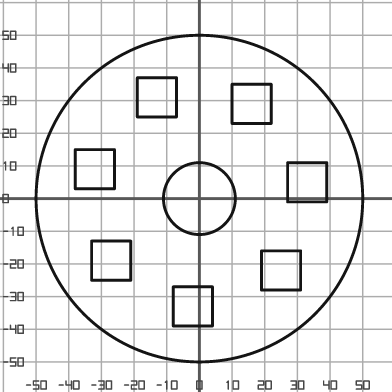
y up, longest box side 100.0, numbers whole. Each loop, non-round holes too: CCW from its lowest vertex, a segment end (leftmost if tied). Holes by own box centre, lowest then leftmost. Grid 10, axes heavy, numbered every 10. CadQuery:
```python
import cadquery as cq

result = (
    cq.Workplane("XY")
    .moveTo(0.0, 0.0)
    .circle(50.0)
    .moveTo(-8.0, -39.0)
    .lineTo(4.0, -39.0)
    .lineTo(4.0, -27.0)
    .lineTo(-8.0, -27.0)
    .close()
    .moveTo(19.0, -28.0)
    .lineTo(31.0, -28.0)
    .lineTo(31.0, -16.0)
    .lineTo(19.0, -16.0)
    .close()
    .moveTo(-33.0, -25.0)
    .lineTo(-21.0, -25.0)
    .lineTo(-21.0, -13.0)
    .lineTo(-33.0, -13.0)
    .close()
    .moveTo(0.0, 0.0)
    .circle(11.0)
    .moveTo(27.0, -1.0)
    .lineTo(39.0, -1.0)
    .lineTo(39.0, 11.0)
    .lineTo(27.0, 11.0)
    .close()
    .moveTo(-38.0, 3.0)
    .lineTo(-26.0, 3.0)
    .lineTo(-26.0, 15.0)
    .lineTo(-38.0, 15.0)
    .close()
    .moveTo(10.0, 23.0)
    .lineTo(22.0, 23.0)
    .lineTo(22.0, 35.0)
    .lineTo(10.0, 35.0)
    .close()
    .moveTo(-19.0, 25.0)
    .lineTo(-7.0, 25.0)
    .lineTo(-7.0, 37.0)
    .lineTo(-19.0, 37.0)
    .close()
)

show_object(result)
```